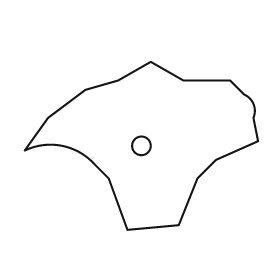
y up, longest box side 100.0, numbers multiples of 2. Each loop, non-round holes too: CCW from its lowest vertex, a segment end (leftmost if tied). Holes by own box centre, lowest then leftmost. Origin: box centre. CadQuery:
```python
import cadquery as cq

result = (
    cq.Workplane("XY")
    .moveTo(-6.0, -36.0)
    .lineTo(16.0, -34.0)
    .lineTo(24.0, -14.0)
    .lineTo(32.0, -6.0)
    .lineTo(50.0, 2.0)
    .lineTo(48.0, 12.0)
    .threePointArc((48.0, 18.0), (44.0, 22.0))
    .lineTo(38.0, 28.0)
    .lineTo(18.0, 28.0)
    .lineTo(4.0, 36.0)
    .lineTo(-10.0, 28.0)
    .lineTo(-24.0, 24.0)
    .lineTo(-40.0, 12.0)
    .lineTo(-50.0, -2.0)
    .threePointArc((-34.0, 0.0), (-20.0, -8.0))
    .lineTo(-14.0, -14.0)
    .close()
    .moveTo(0.0, 0.0)
    .circle(4.0)
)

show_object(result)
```